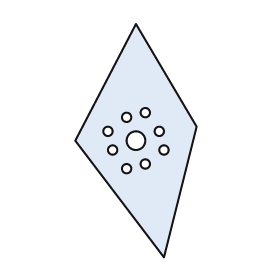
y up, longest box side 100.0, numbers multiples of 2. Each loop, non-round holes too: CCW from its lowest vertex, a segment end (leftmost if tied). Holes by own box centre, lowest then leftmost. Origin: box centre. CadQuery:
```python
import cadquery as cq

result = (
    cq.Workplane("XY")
    .moveTo(12.0, -50.0)
    .lineTo(26.0, 6.0)
    .lineTo(0.0, 50.0)
    .lineTo(-26.0, 0.0)
    .close()
    .moveTo(-4.0, -12.0)
    .circle(2.0)
    .moveTo(4.0, -10.0)
    .circle(2.0)
    .moveTo(-10.0, -4.0)
    .circle(2.0)
    .moveTo(12.0, -4.0)
    .circle(2.0)
    .moveTo(0.0, 0.0)
    .circle(4.0)
    .moveTo(-12.0, 4.0)
    .circle(2.0)
    .moveTo(10.0, 4.0)
    .circle(2.0)
    .moveTo(-4.0, 10.0)
    .circle(2.0)
    .moveTo(4.0, 12.0)
    .circle(2.0)
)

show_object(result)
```